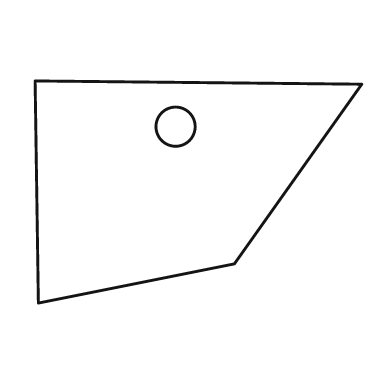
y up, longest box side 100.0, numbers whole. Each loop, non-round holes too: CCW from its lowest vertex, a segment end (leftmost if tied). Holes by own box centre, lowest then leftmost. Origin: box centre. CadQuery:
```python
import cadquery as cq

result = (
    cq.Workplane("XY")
    .moveTo(-49.0, -34.0)
    .lineTo(11.0, -22.0)
    .lineTo(50.0, 33.0)
    .lineTo(-50.0, 34.0)
    .close()
    .moveTo(-7.0, 20.0)
    .circle(6.0)
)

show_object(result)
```